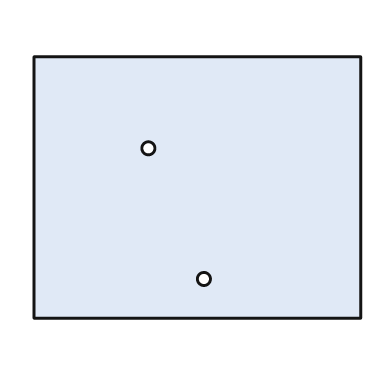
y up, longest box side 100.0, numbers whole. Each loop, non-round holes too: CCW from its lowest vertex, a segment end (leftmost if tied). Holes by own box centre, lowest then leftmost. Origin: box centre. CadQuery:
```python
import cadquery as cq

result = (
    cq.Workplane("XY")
    .moveTo(-50.0, -40.0)
    .lineTo(50.0, -40.0)
    .lineTo(50.0, 40.0)
    .lineTo(-50.0, 40.0)
    .close()
    .moveTo(2.0, -28.0)
    .circle(2.0)
    .moveTo(-15.0, 12.0)
    .circle(2.0)
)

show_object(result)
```